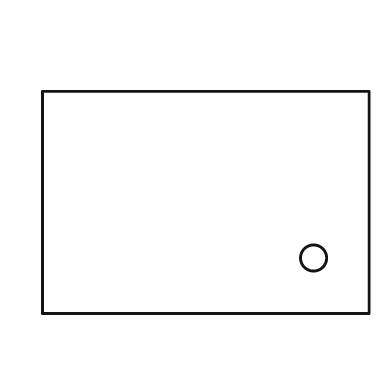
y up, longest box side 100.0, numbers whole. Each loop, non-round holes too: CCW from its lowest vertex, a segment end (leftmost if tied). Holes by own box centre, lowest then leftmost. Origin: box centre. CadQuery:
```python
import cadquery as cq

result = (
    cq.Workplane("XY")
    .moveTo(-50.0, -34.0)
    .lineTo(50.0, -34.0)
    .lineTo(50.0, 34.0)
    .lineTo(-50.0, 34.0)
    .close()
    .moveTo(33.0, -17.0)
    .circle(4.0)
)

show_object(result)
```